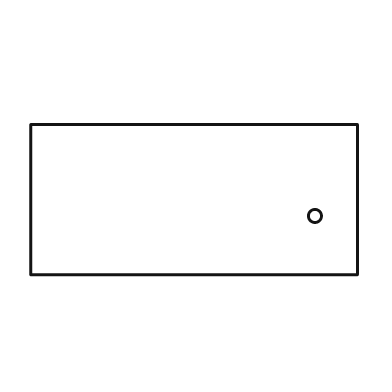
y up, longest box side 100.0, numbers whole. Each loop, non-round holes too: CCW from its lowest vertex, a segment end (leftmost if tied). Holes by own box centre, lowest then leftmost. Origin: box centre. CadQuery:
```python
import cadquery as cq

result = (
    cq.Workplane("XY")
    .moveTo(-50.0, -23.0)
    .lineTo(50.0, -23.0)
    .lineTo(50.0, 23.0)
    .lineTo(-50.0, 23.0)
    .close()
    .moveTo(37.0, -5.0)
    .circle(2.0)
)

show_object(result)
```